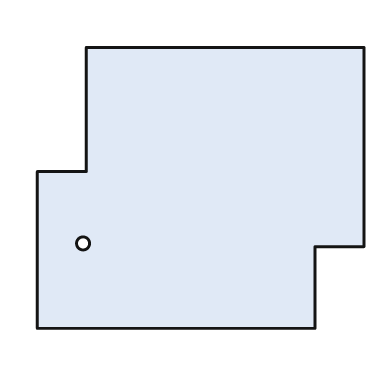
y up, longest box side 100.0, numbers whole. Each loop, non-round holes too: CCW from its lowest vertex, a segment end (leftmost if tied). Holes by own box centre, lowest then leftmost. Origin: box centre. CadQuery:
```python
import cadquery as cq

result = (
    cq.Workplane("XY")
    .moveTo(-50.0, -43.0)
    .lineTo(35.0, -43.0)
    .lineTo(35.0, -18.0)
    .lineTo(50.0, -18.0)
    .lineTo(50.0, 43.0)
    .lineTo(-35.0, 43.0)
    .lineTo(-35.0, 5.0)
    .lineTo(-50.0, 5.0)
    .close()
    .moveTo(-36.0, -17.0)
    .circle(2.0)
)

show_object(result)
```